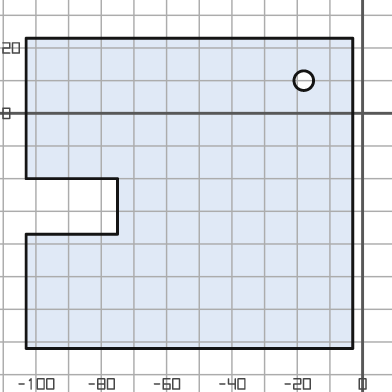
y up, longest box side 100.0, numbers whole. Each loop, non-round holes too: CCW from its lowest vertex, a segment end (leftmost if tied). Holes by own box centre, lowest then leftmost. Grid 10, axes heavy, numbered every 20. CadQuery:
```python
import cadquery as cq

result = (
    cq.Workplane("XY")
    .moveTo(-103.0, -72.0)
    .lineTo(-3.0, -72.0)
    .lineTo(-3.0, 23.0)
    .lineTo(-103.0, 23.0)
    .lineTo(-103.0, -20.0)
    .lineTo(-75.0, -20.0)
    .lineTo(-75.0, -37.0)
    .lineTo(-103.0, -37.0)
    .close()
    .moveTo(-18.0, 10.0)
    .circle(3.0)
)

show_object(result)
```